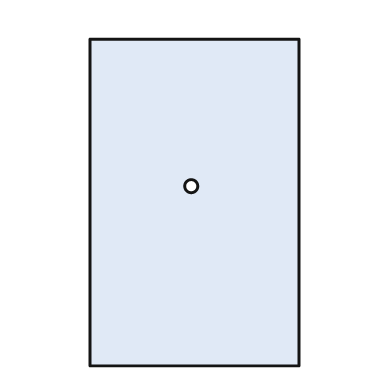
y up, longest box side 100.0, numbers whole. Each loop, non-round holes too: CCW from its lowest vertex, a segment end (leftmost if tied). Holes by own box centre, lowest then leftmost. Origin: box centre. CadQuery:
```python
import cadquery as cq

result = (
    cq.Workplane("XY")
    .moveTo(-32.0, -50.0)
    .lineTo(32.0, -50.0)
    .lineTo(32.0, 50.0)
    .lineTo(-32.0, 50.0)
    .close()
    .moveTo(-1.0, 5.0)
    .circle(2.0)
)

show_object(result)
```